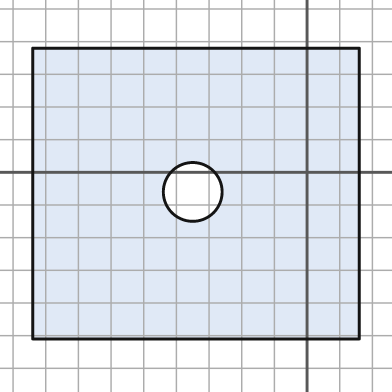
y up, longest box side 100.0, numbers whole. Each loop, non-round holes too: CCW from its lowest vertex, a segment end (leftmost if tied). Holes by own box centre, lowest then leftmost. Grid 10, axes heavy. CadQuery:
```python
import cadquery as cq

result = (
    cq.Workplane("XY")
    .moveTo(-84.0, -51.0)
    .lineTo(16.0, -51.0)
    .lineTo(16.0, 38.0)
    .lineTo(-84.0, 38.0)
    .close()
    .moveTo(-35.0, -6.0)
    .circle(9.0)
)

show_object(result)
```